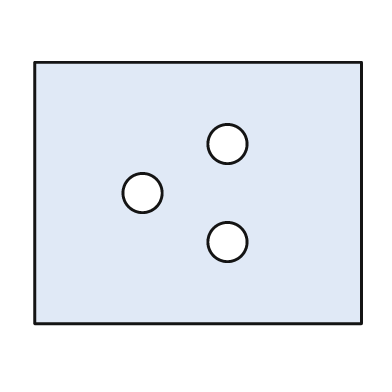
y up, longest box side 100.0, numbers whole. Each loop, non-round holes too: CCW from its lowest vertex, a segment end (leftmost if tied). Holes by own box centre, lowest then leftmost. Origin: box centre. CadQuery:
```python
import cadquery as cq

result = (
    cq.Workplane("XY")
    .moveTo(-50.0, -40.0)
    .lineTo(50.0, -40.0)
    .lineTo(50.0, 40.0)
    .lineTo(-50.0, 40.0)
    .close()
    .moveTo(9.0, -15.0)
    .circle(6.0)
    .moveTo(-17.0, 0.0)
    .circle(6.0)
    .moveTo(9.0, 15.0)
    .circle(6.0)
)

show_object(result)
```